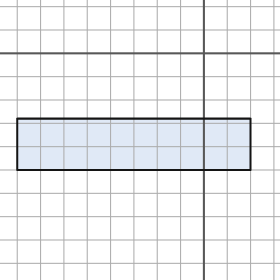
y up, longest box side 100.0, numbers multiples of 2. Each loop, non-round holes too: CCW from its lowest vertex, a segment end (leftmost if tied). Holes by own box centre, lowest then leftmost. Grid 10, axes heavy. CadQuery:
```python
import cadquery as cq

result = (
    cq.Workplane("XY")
    .moveTo(-80.0, -50.0)
    .lineTo(20.0, -50.0)
    .lineTo(20.0, -28.0)
    .lineTo(-80.0, -28.0)
    .close()
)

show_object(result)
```